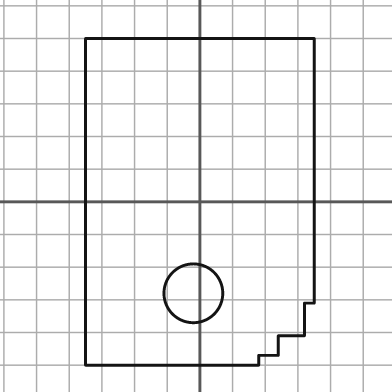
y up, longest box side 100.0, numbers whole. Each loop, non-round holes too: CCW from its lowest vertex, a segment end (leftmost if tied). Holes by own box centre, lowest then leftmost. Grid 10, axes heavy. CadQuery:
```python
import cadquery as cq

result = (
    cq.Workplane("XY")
    .moveTo(-35.0, -50.0)
    .lineTo(18.0, -50.0)
    .lineTo(18.0, -47.0)
    .lineTo(24.0, -47.0)
    .lineTo(24.0, -41.0)
    .lineTo(32.0, -41.0)
    .lineTo(32.0, -31.0)
    .lineTo(35.0, -31.0)
    .lineTo(35.0, 50.0)
    .lineTo(-35.0, 50.0)
    .close()
    .moveTo(-2.0, -28.0)
    .circle(9.0)
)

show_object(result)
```